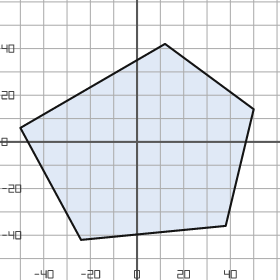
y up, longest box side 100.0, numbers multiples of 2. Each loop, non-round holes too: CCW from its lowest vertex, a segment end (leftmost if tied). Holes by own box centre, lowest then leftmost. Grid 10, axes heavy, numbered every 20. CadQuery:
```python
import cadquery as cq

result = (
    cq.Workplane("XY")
    .moveTo(-24.0, -42.0)
    .lineTo(38.0, -36.0)
    .lineTo(50.0, 14.0)
    .lineTo(12.0, 42.0)
    .lineTo(-50.0, 6.0)
    .close()
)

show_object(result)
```